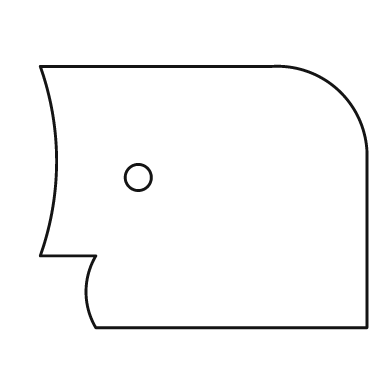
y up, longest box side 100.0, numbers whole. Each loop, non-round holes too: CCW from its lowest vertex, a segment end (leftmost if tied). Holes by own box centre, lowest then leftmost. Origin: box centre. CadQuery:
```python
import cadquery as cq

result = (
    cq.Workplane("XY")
    .moveTo(-33.0, -40.0)
    .lineTo(50.0, -40.0)
    .lineTo(50.0, 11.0)
    .threePointArc((42.0, 32.0), (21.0, 40.0))
    .lineTo(-50.0, 40.0)
    .threePointArc((-45.0, 11.0), (-50.0, -18.0))
    .lineTo(-33.0, -18.0)
    .threePointArc((-36.0, -29.0), (-33.0, -40.0))
    .close()
    .moveTo(-20.0, 6.0)
    .circle(4.0)
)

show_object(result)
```